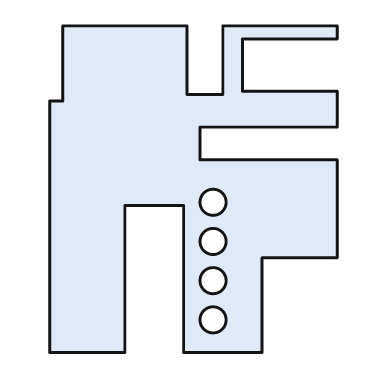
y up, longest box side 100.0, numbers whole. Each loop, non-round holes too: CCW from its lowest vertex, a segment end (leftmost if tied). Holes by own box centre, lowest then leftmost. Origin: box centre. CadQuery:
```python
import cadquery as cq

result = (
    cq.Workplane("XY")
    .moveTo(-44.0, -50.0)
    .lineTo(-21.0, -50.0)
    .lineTo(-21.0, -5.0)
    .lineTo(-3.0, -5.0)
    .lineTo(-3.0, -50.0)
    .lineTo(21.0, -50.0)
    .lineTo(21.0, -21.0)
    .lineTo(44.0, -21.0)
    .lineTo(44.0, 9.0)
    .lineTo(2.0, 9.0)
    .lineTo(2.0, 19.0)
    .lineTo(44.0, 19.0)
    .lineTo(44.0, 30.0)
    .lineTo(15.0, 30.0)
    .lineTo(15.0, 46.0)
    .lineTo(44.0, 46.0)
    .lineTo(44.0, 50.0)
    .lineTo(9.0, 50.0)
    .lineTo(9.0, 29.0)
    .lineTo(-2.0, 29.0)
    .lineTo(-2.0, 50.0)
    .lineTo(-40.0, 50.0)
    .lineTo(-40.0, 27.0)
    .lineTo(-44.0, 27.0)
    .close()
    .moveTo(6.0, -40.0)
    .circle(4.0)
    .moveTo(6.0, -28.0)
    .circle(4.0)
    .moveTo(6.0, -16.0)
    .circle(4.0)
    .moveTo(6.0, -4.0)
    .circle(4.0)
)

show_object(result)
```